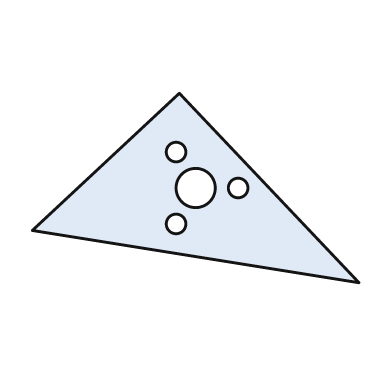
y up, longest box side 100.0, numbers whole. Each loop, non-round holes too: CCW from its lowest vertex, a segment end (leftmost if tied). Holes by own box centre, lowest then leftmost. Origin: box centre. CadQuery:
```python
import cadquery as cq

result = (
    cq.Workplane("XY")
    .moveTo(50.0, -29.0)
    .lineTo(-5.0, 29.0)
    .lineTo(-50.0, -13.0)
    .close()
    .moveTo(-6.0, -11.0)
    .circle(3.0)
    .moveTo(0.0, 0.0)
    .circle(6.0)
    .moveTo(13.0, 0.0)
    .circle(3.0)
    .moveTo(-6.0, 11.0)
    .circle(3.0)
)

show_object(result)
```